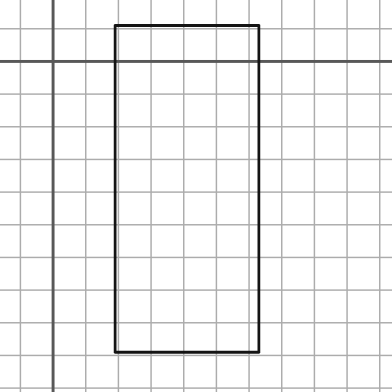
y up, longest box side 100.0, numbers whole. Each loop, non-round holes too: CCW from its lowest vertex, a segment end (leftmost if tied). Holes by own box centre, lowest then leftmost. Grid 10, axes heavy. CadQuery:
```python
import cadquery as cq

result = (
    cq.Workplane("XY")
    .moveTo(19.0, -89.0)
    .lineTo(63.0, -89.0)
    .lineTo(63.0, 11.0)
    .lineTo(19.0, 11.0)
    .close()
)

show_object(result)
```